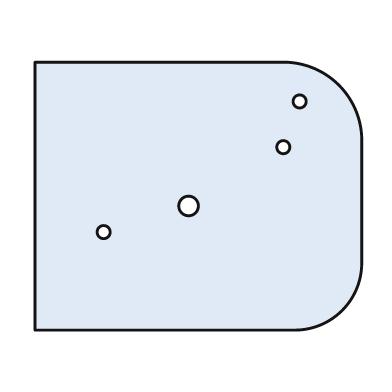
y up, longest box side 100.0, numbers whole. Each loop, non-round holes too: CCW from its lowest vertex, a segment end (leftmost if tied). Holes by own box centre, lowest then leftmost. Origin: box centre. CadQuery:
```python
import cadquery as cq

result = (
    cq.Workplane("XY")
    .moveTo(-50.0, -41.0)
    .lineTo(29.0, -41.0)
    .threePointArc((44.0, -35.0), (50.0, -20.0))
    .lineTo(50.0, 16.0)
    .threePointArc((43.0, 34.0), (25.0, 41.0))
    .lineTo(-50.0, 41.0)
    .close()
    .moveTo(-29.0, -11.0)
    .circle(2.0)
    .moveTo(-3.0, -3.0)
    .circle(3.0)
    .moveTo(26.0, 15.0)
    .circle(2.0)
    .moveTo(31.0, 29.0)
    .circle(2.0)
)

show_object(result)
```